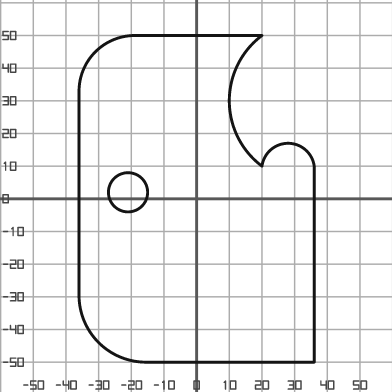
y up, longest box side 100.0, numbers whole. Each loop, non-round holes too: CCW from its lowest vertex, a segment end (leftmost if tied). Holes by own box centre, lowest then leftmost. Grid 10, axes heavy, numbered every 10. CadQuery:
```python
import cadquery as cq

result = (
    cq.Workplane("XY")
    .moveTo(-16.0, -50.0)
    .lineTo(36.0, -50.0)
    .lineTo(36.0, 10.0)
    .threePointArc((28.0, 17.0), (20.0, 10.0))
    .threePointArc((10.0, 30.0), (20.0, 50.0))
    .lineTo(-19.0, 50.0)
    .threePointArc((-31.0, 45.0), (-36.0, 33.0))
    .lineTo(-36.0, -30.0)
    .threePointArc((-30.0, -44.0), (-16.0, -50.0))
    .close()
    .moveTo(-21.0, 2.0)
    .circle(6.0)
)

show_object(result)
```